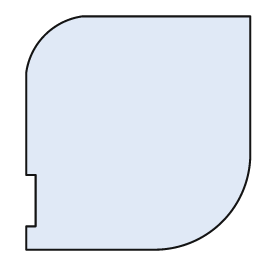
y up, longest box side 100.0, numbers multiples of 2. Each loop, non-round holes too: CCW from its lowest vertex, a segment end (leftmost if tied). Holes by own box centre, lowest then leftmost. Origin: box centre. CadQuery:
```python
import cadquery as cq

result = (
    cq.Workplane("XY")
    .moveTo(-48.0, -50.0)
    .lineTo(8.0, -50.0)
    .threePointArc((36.0, -38.0), (48.0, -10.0))
    .lineTo(48.0, 50.0)
    .lineTo(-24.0, 50.0)
    .threePointArc((-40.0, 42.0), (-48.0, 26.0))
    .lineTo(-48.0, -18.0)
    .lineTo(-44.0, -18.0)
    .lineTo(-44.0, -40.0)
    .lineTo(-48.0, -40.0)
    .close()
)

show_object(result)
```